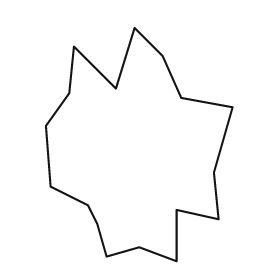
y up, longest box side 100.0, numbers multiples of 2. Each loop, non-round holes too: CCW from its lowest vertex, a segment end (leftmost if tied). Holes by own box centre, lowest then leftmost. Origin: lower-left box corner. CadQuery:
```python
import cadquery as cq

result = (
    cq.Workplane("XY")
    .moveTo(56.0, 0.0)
    .lineTo(56.0, 22.0)
    .lineTo(74.0, 18.0)
    .lineTo(72.0, 38.0)
    .lineTo(80.0, 66.0)
    .lineTo(58.0, 70.0)
    .lineTo(50.0, 88.0)
    .lineTo(38.0, 100.0)
    .lineTo(30.0, 74.0)
    .lineTo(12.0, 92.0)
    .lineTo(10.0, 72.0)
    .lineTo(0.0, 58.0)
    .lineTo(2.0, 32.0)
    .lineTo(18.0, 24.0)
    .lineTo(22.0, 16.0)
    .lineTo(26.0, 2.0)
    .lineTo(40.0, 6.0)
    .close()
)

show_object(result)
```